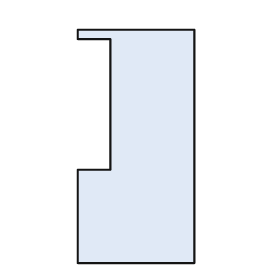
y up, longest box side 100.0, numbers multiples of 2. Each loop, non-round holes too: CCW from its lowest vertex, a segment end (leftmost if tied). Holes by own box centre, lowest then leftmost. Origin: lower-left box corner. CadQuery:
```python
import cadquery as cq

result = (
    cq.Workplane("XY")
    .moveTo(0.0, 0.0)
    .lineTo(50.0, 0.0)
    .lineTo(50.0, 100.0)
    .lineTo(0.0, 100.0)
    .lineTo(0.0, 96.0)
    .lineTo(14.0, 96.0)
    .lineTo(14.0, 40.0)
    .lineTo(0.0, 40.0)
    .close()
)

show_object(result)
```